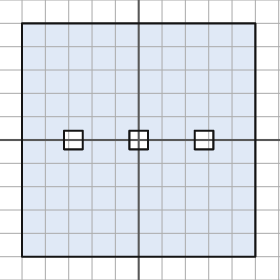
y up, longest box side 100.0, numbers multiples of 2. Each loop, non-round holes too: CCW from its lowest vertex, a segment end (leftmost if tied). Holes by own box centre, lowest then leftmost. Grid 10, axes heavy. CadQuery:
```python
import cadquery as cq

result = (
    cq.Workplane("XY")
    .moveTo(-50.0, -50.0)
    .lineTo(50.0, -50.0)
    .lineTo(50.0, 50.0)
    .lineTo(-50.0, 50.0)
    .close()
    .moveTo(-32.0, -4.0)
    .lineTo(-24.0, -4.0)
    .lineTo(-24.0, 4.0)
    .lineTo(-32.0, 4.0)
    .close()
    .moveTo(-4.0, -4.0)
    .lineTo(4.0, -4.0)
    .lineTo(4.0, 4.0)
    .lineTo(-4.0, 4.0)
    .close()
    .moveTo(24.0, -4.0)
    .lineTo(32.0, -4.0)
    .lineTo(32.0, 4.0)
    .lineTo(24.0, 4.0)
    .close()
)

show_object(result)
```